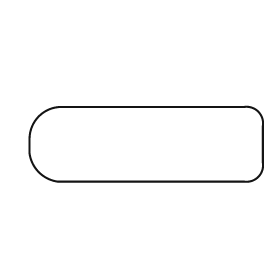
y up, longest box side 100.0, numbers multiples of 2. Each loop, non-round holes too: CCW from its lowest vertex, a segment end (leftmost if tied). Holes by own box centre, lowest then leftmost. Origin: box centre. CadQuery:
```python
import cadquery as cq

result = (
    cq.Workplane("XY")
    .moveTo(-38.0, -16.0)
    .lineTo(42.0, -16.0)
    .threePointArc((48.0, -14.0), (50.0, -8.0))
    .lineTo(50.0, 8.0)
    .threePointArc((48.0, 14.0), (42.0, 16.0))
    .lineTo(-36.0, 16.0)
    .threePointArc((-46.0, 12.0), (-50.0, 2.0))
    .lineTo(-50.0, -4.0)
    .threePointArc((-46.0, -12.0), (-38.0, -16.0))
    .close()
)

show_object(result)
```